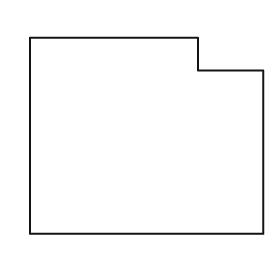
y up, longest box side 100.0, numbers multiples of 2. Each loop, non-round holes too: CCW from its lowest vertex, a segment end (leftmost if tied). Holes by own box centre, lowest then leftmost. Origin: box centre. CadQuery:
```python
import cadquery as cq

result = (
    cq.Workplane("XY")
    .moveTo(-50.0, -42.0)
    .lineTo(50.0, -42.0)
    .lineTo(50.0, 28.0)
    .lineTo(22.0, 28.0)
    .lineTo(22.0, 42.0)
    .lineTo(-50.0, 42.0)
    .close()
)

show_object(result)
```